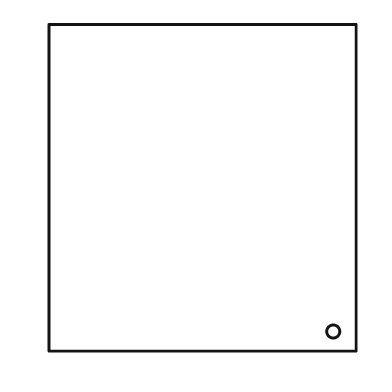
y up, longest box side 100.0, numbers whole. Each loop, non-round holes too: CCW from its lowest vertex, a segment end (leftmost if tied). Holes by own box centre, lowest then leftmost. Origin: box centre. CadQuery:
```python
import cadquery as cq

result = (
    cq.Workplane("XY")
    .moveTo(-47.0, -50.0)
    .lineTo(47.0, -50.0)
    .lineTo(47.0, 50.0)
    .lineTo(-47.0, 50.0)
    .close()
    .moveTo(40.0, -44.0)
    .circle(2.0)
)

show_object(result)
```